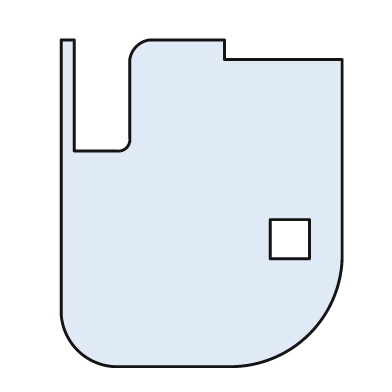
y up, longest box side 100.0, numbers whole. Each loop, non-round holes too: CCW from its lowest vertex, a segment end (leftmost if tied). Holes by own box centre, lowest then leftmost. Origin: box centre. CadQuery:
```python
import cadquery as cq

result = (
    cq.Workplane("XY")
    .moveTo(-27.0, -50.0)
    .lineTo(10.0, -50.0)
    .threePointArc((33.0, -40.0), (43.0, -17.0))
    .lineTo(43.0, 44.0)
    .lineTo(7.0, 44.0)
    .lineTo(7.0, 50.0)
    .lineTo(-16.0, 50.0)
    .threePointArc((-20.0, 48.0), (-22.0, 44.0))
    .lineTo(-22.0, 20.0)
    .threePointArc((-23.0, 17.0), (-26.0, 16.0))
    .lineTo(-39.0, 16.0)
    .lineTo(-39.0, 50.0)
    .lineTo(-43.0, 50.0)
    .lineTo(-43.0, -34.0)
    .threePointArc((-38.0, -45.0), (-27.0, -50.0))
    .close()
    .moveTo(21.0, -17.0)
    .lineTo(33.0, -17.0)
    .lineTo(33.0, -5.0)
    .lineTo(21.0, -5.0)
    .close()
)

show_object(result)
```